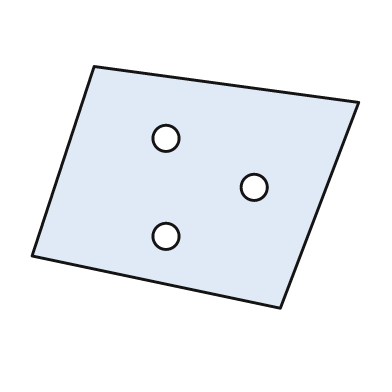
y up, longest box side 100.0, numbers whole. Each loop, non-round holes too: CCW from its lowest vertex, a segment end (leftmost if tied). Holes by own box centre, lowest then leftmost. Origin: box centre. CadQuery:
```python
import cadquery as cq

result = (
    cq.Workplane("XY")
    .moveTo(26.0, -37.0)
    .lineTo(50.0, 26.0)
    .lineTo(-31.0, 37.0)
    .lineTo(-50.0, -21.0)
    .close()
    .moveTo(-9.0, -15.0)
    .circle(4.0)
    .moveTo(18.0, 0.0)
    .circle(4.0)
    .moveTo(-9.0, 15.0)
    .circle(4.0)
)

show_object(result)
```